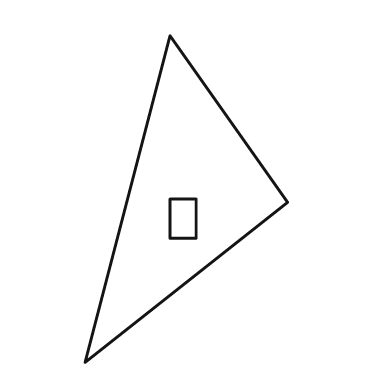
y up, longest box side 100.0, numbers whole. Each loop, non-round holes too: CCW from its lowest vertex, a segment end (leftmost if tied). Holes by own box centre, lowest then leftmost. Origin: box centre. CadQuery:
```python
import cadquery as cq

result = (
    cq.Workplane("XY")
    .moveTo(-31.0, -50.0)
    .lineTo(31.0, -1.0)
    .lineTo(-5.0, 50.0)
    .close()
    .moveTo(-5.0, -12.0)
    .lineTo(3.0, -12.0)
    .lineTo(3.0, 0.0)
    .lineTo(-5.0, 0.0)
    .close()
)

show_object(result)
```